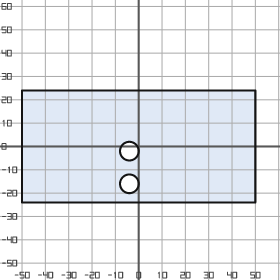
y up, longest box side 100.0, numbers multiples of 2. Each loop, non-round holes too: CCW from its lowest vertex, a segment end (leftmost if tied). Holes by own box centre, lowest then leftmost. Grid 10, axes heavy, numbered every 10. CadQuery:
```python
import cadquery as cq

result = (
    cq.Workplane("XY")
    .moveTo(-50.0, -24.0)
    .lineTo(50.0, -24.0)
    .lineTo(50.0, 24.0)
    .lineTo(-50.0, 24.0)
    .close()
    .moveTo(-4.0, -16.0)
    .circle(4.0)
    .moveTo(-4.0, -2.0)
    .circle(4.0)
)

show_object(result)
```